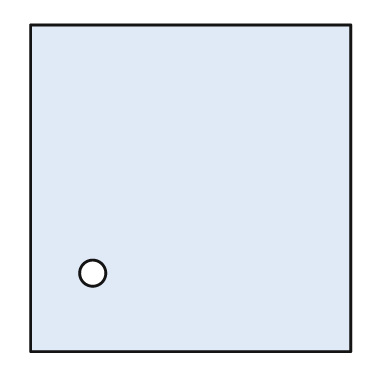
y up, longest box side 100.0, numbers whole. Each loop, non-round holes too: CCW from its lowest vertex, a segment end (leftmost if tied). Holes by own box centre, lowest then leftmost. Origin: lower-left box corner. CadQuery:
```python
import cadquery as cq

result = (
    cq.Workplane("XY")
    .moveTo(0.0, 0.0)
    .lineTo(98.0, 0.0)
    .lineTo(98.0, 100.0)
    .lineTo(0.0, 100.0)
    .close()
    .moveTo(19.0, 24.0)
    .circle(4.0)
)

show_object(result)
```